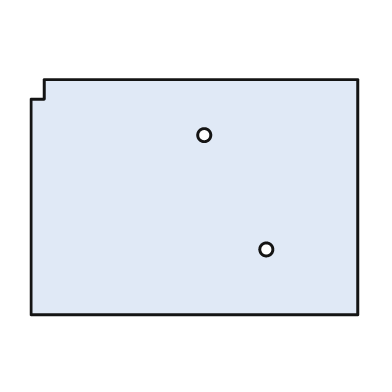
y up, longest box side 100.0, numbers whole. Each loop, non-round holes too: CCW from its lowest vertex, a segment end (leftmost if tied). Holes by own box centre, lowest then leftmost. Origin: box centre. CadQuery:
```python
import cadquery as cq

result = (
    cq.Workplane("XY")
    .moveTo(-50.0, -36.0)
    .lineTo(50.0, -36.0)
    .lineTo(50.0, 36.0)
    .lineTo(-46.0, 36.0)
    .lineTo(-46.0, 30.0)
    .lineTo(-50.0, 30.0)
    .close()
    .moveTo(22.0, -16.0)
    .circle(2.0)
    .moveTo(3.0, 19.0)
    .circle(2.0)
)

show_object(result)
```